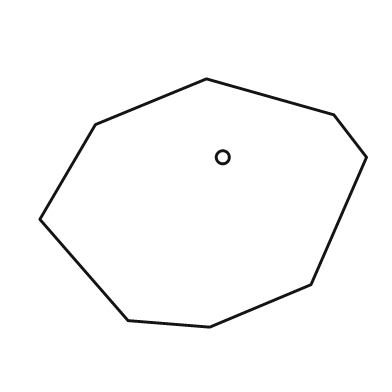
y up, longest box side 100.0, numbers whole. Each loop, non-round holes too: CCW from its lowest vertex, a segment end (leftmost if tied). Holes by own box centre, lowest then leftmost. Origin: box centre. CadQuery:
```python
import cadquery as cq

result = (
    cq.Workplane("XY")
    .moveTo(2.0, -38.0)
    .lineTo(33.0, -25.0)
    .lineTo(50.0, 14.0)
    .lineTo(40.0, 27.0)
    .lineTo(1.0, 38.0)
    .lineTo(-33.0, 24.0)
    .lineTo(-50.0, -5.0)
    .lineTo(-23.0, -36.0)
    .close()
    .moveTo(6.0, 14.0)
    .circle(2.0)
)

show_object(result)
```